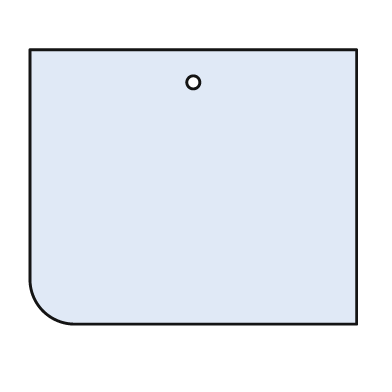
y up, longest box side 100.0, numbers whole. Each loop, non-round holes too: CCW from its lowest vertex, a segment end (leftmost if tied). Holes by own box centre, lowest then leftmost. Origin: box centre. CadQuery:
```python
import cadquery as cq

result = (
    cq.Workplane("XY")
    .moveTo(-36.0, -42.0)
    .lineTo(50.0, -42.0)
    .lineTo(50.0, 42.0)
    .lineTo(-50.0, 42.0)
    .lineTo(-50.0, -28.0)
    .threePointArc((-46.0, -38.0), (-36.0, -42.0))
    .close()
    .moveTo(0.0, 32.0)
    .circle(2.0)
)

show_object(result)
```